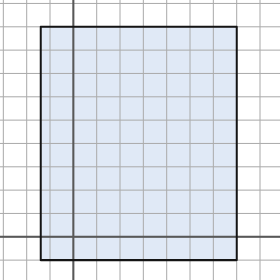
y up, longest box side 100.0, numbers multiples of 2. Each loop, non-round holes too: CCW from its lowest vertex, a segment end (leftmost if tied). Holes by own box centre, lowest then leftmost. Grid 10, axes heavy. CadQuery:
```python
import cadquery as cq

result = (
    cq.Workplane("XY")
    .moveTo(-14.0, -10.0)
    .lineTo(70.0, -10.0)
    .lineTo(70.0, 90.0)
    .lineTo(-14.0, 90.0)
    .close()
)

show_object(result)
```